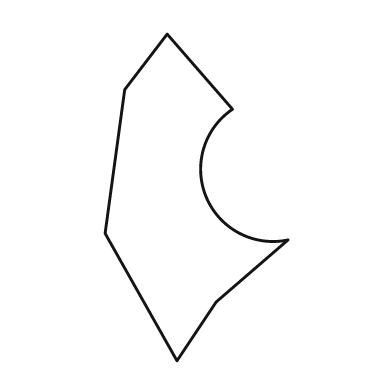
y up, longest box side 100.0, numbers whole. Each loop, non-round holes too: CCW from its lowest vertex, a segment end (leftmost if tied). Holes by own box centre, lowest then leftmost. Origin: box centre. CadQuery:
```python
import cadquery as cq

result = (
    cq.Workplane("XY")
    .moveTo(-6.0, -50.0)
    .lineTo(6.0, -32.0)
    .lineTo(28.0, -13.0)
    .threePointArc((3.0, 0.0), (11.0, 27.0))
    .lineTo(-9.0, 50.0)
    .lineTo(-22.0, 33.0)
    .lineTo(-28.0, -11.0)
    .close()
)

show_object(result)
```